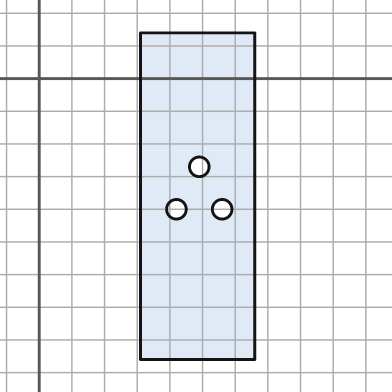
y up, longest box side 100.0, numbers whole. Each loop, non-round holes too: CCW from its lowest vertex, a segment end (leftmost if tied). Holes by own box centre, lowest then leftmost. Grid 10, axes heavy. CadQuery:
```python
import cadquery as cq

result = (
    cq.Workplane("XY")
    .moveTo(31.0, -86.0)
    .lineTo(66.0, -86.0)
    .lineTo(66.0, 14.0)
    .lineTo(31.0, 14.0)
    .close()
    .moveTo(42.0, -40.0)
    .circle(3.0)
    .moveTo(56.0, -40.0)
    .circle(3.0)
    .moveTo(49.0, -27.0)
    .circle(3.0)
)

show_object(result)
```